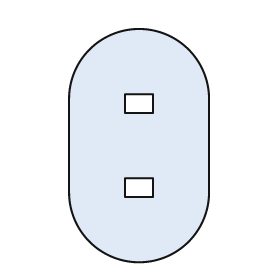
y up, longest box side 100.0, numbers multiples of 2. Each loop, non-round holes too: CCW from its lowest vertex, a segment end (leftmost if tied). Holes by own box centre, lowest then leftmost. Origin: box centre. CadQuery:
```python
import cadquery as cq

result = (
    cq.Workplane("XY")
    .moveTo(-30.0, -20.0)
    .threePointArc((0.0, -50.0), (30.0, -20.0))
    .lineTo(30.0, 20.0)
    .threePointArc((0.0, 50.0), (-30.0, 20.0))
    .close()
    .moveTo(-6.0, -22.0)
    .lineTo(6.0, -22.0)
    .lineTo(6.0, -14.0)
    .lineTo(-6.0, -14.0)
    .close()
    .moveTo(-6.0, 14.0)
    .lineTo(6.0, 14.0)
    .lineTo(6.0, 22.0)
    .lineTo(-6.0, 22.0)
    .close()
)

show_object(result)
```